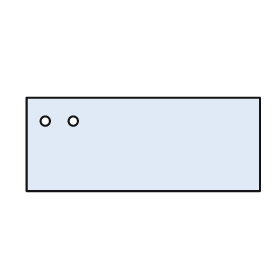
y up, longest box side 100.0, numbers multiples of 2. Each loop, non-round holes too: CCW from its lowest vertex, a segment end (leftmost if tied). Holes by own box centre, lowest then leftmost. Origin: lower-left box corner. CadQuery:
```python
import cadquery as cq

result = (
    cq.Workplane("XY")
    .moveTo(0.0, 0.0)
    .lineTo(100.0, 0.0)
    .lineTo(100.0, 40.0)
    .lineTo(0.0, 40.0)
    .close()
    .moveTo(8.0, 30.0)
    .circle(2.0)
    .moveTo(20.0, 30.0)
    .circle(2.0)
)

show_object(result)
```